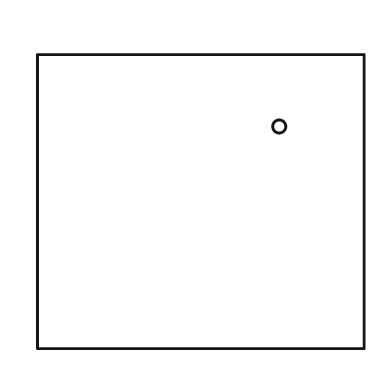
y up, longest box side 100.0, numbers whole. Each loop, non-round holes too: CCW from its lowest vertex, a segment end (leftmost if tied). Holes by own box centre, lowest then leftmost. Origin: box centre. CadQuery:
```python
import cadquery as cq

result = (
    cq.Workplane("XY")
    .moveTo(-50.0, -45.0)
    .lineTo(50.0, -45.0)
    .lineTo(50.0, 45.0)
    .lineTo(-50.0, 45.0)
    .close()
    .moveTo(24.0, 23.0)
    .circle(2.0)
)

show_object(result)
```